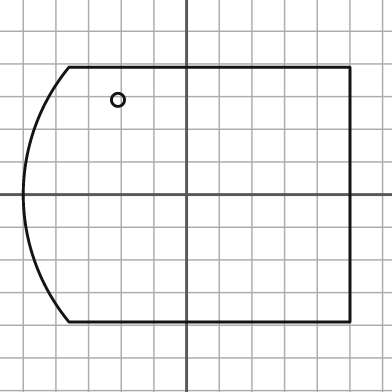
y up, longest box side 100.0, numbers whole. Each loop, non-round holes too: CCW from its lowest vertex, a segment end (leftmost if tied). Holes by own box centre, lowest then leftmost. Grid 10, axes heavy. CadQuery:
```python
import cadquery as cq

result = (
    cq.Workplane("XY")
    .moveTo(-36.0, -39.0)
    .lineTo(50.0, -39.0)
    .lineTo(50.0, 39.0)
    .lineTo(-36.0, 39.0)
    .threePointArc((-50.0, 0.0), (-36.0, -39.0))
    .close()
    .moveTo(-21.0, 29.0)
    .circle(2.0)
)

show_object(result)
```